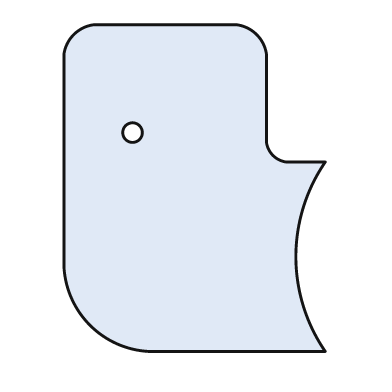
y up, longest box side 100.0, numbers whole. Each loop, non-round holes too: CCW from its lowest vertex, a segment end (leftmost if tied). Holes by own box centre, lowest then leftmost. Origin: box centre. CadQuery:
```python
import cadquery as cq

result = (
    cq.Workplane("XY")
    .moveTo(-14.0, -50.0)
    .lineTo(40.0, -50.0)
    .threePointArc((31.0, -21.0), (40.0, 8.0))
    .lineTo(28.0, 8.0)
    .threePointArc((24.0, 10.0), (22.0, 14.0))
    .lineTo(22.0, 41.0)
    .threePointArc((19.0, 47.0), (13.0, 50.0))
    .lineTo(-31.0, 50.0)
    .threePointArc((-37.0, 47.0), (-40.0, 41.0))
    .lineTo(-40.0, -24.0)
    .threePointArc((-32.0, -42.0), (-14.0, -50.0))
    .close()
    .moveTo(-19.0, 17.0)
    .circle(3.0)
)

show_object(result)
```